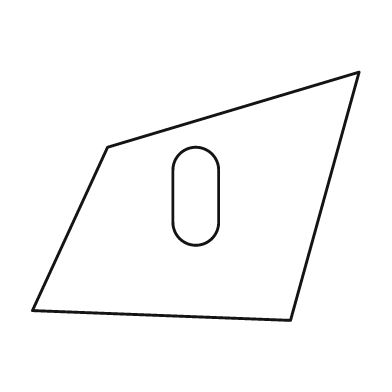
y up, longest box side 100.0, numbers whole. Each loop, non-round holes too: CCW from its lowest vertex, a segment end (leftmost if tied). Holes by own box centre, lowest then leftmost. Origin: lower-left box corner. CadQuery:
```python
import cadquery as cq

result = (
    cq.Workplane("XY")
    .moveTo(79.0, 0.0)
    .lineTo(100.0, 76.0)
    .lineTo(23.0, 53.0)
    .lineTo(0.0, 3.0)
    .close()
    .moveTo(43.0, 30.0)
    .threePointArc((50.0, 23.0), (57.0, 30.0))
    .lineTo(57.0, 46.0)
    .threePointArc((50.0, 53.0), (43.0, 46.0))
    .close()
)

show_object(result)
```